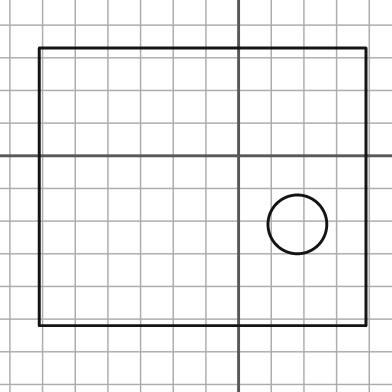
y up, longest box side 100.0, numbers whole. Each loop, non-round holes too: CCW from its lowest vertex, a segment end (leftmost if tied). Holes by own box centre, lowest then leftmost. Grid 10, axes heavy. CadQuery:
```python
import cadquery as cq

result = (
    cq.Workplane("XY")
    .moveTo(-61.0, -52.0)
    .lineTo(39.0, -52.0)
    .lineTo(39.0, 33.0)
    .lineTo(-61.0, 33.0)
    .close()
    .moveTo(18.0, -21.0)
    .circle(9.0)
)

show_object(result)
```